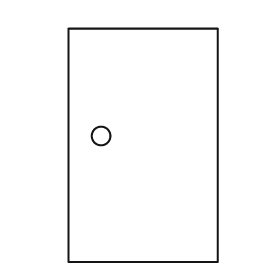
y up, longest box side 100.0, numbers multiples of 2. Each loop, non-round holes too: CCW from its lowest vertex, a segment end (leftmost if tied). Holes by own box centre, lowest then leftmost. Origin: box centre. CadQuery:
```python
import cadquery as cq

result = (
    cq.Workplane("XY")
    .moveTo(-32.0, -50.0)
    .lineTo(32.0, -50.0)
    .lineTo(32.0, 50.0)
    .lineTo(-32.0, 50.0)
    .close()
    .moveTo(-18.0, 4.0)
    .circle(4.0)
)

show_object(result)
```